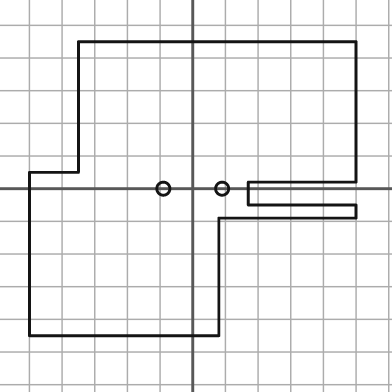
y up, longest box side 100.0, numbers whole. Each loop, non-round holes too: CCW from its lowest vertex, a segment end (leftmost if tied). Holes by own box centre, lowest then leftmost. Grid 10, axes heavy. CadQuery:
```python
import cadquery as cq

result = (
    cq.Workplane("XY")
    .moveTo(-50.0, -45.0)
    .lineTo(8.0, -45.0)
    .lineTo(8.0, -9.0)
    .lineTo(50.0, -9.0)
    .lineTo(50.0, -5.0)
    .lineTo(17.0, -5.0)
    .lineTo(17.0, 2.0)
    .lineTo(50.0, 2.0)
    .lineTo(50.0, 45.0)
    .lineTo(-35.0, 45.0)
    .lineTo(-35.0, 5.0)
    .lineTo(-50.0, 5.0)
    .close()
    .moveTo(-9.0, 0.0)
    .circle(2.0)
    .moveTo(9.0, 0.0)
    .circle(2.0)
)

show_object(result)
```